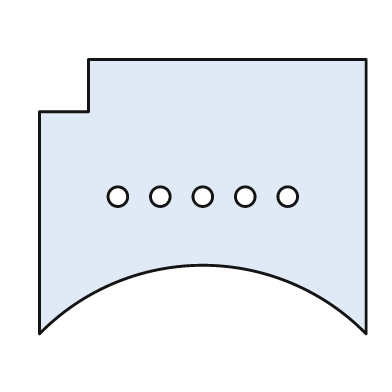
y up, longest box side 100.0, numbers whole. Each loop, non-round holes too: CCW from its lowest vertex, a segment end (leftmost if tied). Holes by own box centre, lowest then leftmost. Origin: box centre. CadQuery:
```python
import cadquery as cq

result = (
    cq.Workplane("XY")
    .moveTo(-50.0, -42.0)
    .threePointArc((0.0, -21.0), (50.0, -42.0))
    .lineTo(50.0, 42.0)
    .lineTo(-35.0, 42.0)
    .lineTo(-35.0, 26.0)
    .lineTo(-50.0, 26.0)
    .close()
    .moveTo(-26.0, 0.0)
    .circle(3.0)
    .moveTo(-13.0, 0.0)
    .circle(3.0)
    .moveTo(0.0, 0.0)
    .circle(3.0)
    .moveTo(13.0, 0.0)
    .circle(3.0)
    .moveTo(26.0, 0.0)
    .circle(3.0)
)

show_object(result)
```